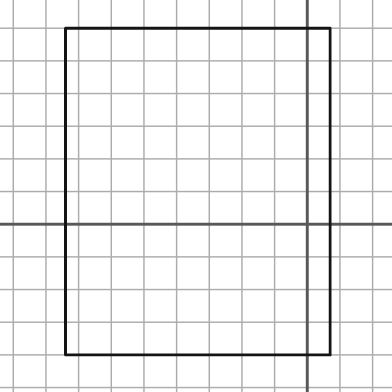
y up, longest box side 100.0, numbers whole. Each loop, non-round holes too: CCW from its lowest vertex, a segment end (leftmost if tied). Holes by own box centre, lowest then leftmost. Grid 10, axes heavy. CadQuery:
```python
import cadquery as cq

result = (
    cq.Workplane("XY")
    .moveTo(-74.0, -40.0)
    .lineTo(7.0, -40.0)
    .lineTo(7.0, 60.0)
    .lineTo(-74.0, 60.0)
    .close()
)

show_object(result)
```